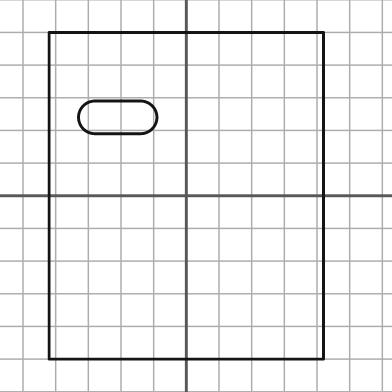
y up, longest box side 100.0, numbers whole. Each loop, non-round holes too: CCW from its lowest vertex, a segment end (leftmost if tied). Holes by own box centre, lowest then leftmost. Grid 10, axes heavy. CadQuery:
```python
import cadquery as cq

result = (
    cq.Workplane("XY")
    .moveTo(-42.0, -50.0)
    .lineTo(42.0, -50.0)
    .lineTo(42.0, 50.0)
    .lineTo(-42.0, 50.0)
    .close()
    .moveTo(-28.0, 19.0)
    .lineTo(-14.0, 19.0)
    .threePointArc((-9.0, 24.0), (-14.0, 29.0))
    .lineTo(-28.0, 29.0)
    .threePointArc((-33.0, 24.0), (-28.0, 19.0))
    .close()
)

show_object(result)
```